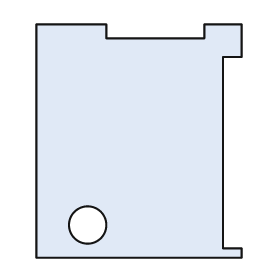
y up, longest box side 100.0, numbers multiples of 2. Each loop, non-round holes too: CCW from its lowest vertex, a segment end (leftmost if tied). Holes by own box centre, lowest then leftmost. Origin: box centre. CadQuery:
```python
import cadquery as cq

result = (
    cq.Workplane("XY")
    .moveTo(-44.0, -50.0)
    .lineTo(44.0, -50.0)
    .lineTo(44.0, -46.0)
    .lineTo(36.0, -46.0)
    .lineTo(36.0, 36.0)
    .lineTo(44.0, 36.0)
    .lineTo(44.0, 50.0)
    .lineTo(28.0, 50.0)
    .lineTo(28.0, 44.0)
    .lineTo(-14.0, 44.0)
    .lineTo(-14.0, 50.0)
    .lineTo(-44.0, 50.0)
    .close()
    .moveTo(-22.0, -36.0)
    .circle(8.0)
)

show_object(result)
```